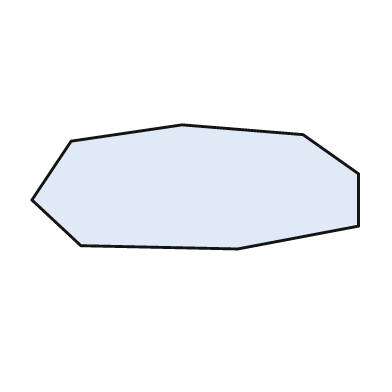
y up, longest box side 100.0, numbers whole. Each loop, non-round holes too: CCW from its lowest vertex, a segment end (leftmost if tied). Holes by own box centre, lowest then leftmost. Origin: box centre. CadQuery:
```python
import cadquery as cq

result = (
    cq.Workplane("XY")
    .moveTo(13.0, -19.0)
    .lineTo(50.0, -12.0)
    .lineTo(50.0, 4.0)
    .lineTo(33.0, 16.0)
    .lineTo(-4.0, 19.0)
    .lineTo(-38.0, 14.0)
    .lineTo(-50.0, -4.0)
    .lineTo(-35.0, -18.0)
    .close()
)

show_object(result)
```